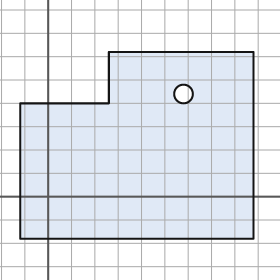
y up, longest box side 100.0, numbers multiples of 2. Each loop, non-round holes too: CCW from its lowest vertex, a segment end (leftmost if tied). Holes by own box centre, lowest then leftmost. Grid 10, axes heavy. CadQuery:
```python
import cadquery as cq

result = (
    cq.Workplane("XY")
    .moveTo(-12.0, -18.0)
    .lineTo(88.0, -18.0)
    .lineTo(88.0, 62.0)
    .lineTo(26.0, 62.0)
    .lineTo(26.0, 40.0)
    .lineTo(-12.0, 40.0)
    .close()
    .moveTo(58.0, 44.0)
    .circle(4.0)
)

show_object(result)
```